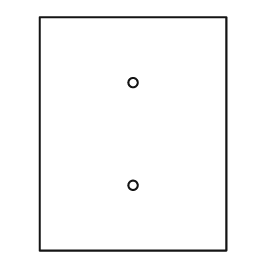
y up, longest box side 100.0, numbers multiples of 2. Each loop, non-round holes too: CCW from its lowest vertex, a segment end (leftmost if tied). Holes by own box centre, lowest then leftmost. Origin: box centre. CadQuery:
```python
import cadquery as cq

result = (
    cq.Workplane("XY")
    .moveTo(-40.0, -50.0)
    .lineTo(40.0, -50.0)
    .lineTo(40.0, 50.0)
    .lineTo(-40.0, 50.0)
    .close()
    .moveTo(0.0, -22.0)
    .circle(2.0)
    .moveTo(0.0, 22.0)
    .circle(2.0)
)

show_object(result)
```